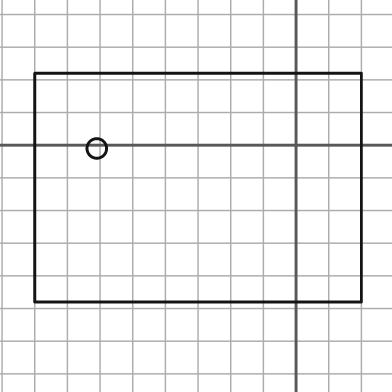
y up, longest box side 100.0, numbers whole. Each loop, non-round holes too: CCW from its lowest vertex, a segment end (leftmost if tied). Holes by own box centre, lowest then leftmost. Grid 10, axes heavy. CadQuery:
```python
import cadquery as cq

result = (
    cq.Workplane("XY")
    .moveTo(-80.0, -48.0)
    .lineTo(20.0, -48.0)
    .lineTo(20.0, 22.0)
    .lineTo(-80.0, 22.0)
    .close()
    .moveTo(-61.0, -1.0)
    .circle(3.0)
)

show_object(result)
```